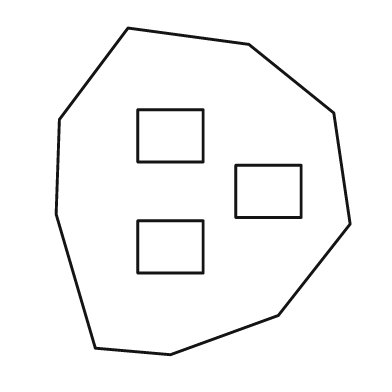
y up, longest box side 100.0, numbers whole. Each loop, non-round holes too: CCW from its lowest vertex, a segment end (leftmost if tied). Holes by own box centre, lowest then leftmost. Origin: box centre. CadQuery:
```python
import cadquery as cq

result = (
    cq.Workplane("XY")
    .moveTo(-10.0, -50.0)
    .lineTo(23.0, -38.0)
    .lineTo(45.0, -10.0)
    .lineTo(40.0, 24.0)
    .lineTo(14.0, 45.0)
    .lineTo(-23.0, 50.0)
    .lineTo(-44.0, 22.0)
    .lineTo(-45.0, -7.0)
    .lineTo(-33.0, -48.0)
    .close()
    .moveTo(-20.0, -25.0)
    .lineTo(0.0, -25.0)
    .lineTo(0.0, -9.0)
    .lineTo(-20.0, -9.0)
    .close()
    .moveTo(10.0, -8.0)
    .lineTo(30.0, -8.0)
    .lineTo(30.0, 8.0)
    .lineTo(10.0, 8.0)
    .close()
    .moveTo(-20.0, 9.0)
    .lineTo(0.0, 9.0)
    .lineTo(0.0, 25.0)
    .lineTo(-20.0, 25.0)
    .close()
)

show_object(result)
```